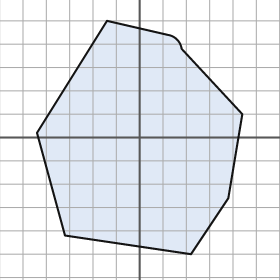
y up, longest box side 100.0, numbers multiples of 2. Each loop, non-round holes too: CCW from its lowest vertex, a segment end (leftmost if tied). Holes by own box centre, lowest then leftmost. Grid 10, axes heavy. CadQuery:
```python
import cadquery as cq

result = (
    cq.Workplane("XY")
    .moveTo(22.0, -50.0)
    .lineTo(38.0, -26.0)
    .lineTo(44.0, 10.0)
    .lineTo(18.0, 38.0)
    .threePointArc((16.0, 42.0), (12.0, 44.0))
    .lineTo(-14.0, 50.0)
    .lineTo(-44.0, 2.0)
    .lineTo(-32.0, -42.0)
    .close()
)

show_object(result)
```